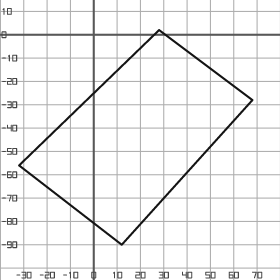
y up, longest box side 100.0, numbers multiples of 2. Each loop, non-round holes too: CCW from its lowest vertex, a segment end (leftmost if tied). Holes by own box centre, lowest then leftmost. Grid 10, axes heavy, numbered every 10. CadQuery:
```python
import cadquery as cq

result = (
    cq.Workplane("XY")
    .moveTo(12.0, -90.0)
    .lineTo(68.0, -28.0)
    .lineTo(28.0, 2.0)
    .lineTo(-32.0, -56.0)
    .close()
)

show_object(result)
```